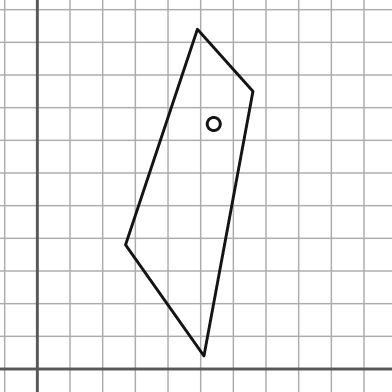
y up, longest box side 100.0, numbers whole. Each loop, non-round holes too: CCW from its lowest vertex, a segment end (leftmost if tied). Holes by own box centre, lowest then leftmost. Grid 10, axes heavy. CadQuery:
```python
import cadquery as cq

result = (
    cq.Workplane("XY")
    .moveTo(51.0, 4.0)
    .lineTo(66.0, 85.0)
    .lineTo(49.0, 104.0)
    .lineTo(27.0, 38.0)
    .close()
    .moveTo(54.0, 75.0)
    .circle(2.0)
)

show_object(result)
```